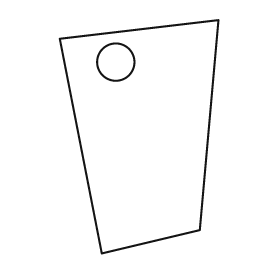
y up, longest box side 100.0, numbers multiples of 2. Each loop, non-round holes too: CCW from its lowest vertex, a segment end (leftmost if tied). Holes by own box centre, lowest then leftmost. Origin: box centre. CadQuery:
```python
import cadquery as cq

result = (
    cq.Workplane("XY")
    .moveTo(-16.0, -50.0)
    .lineTo(26.0, -40.0)
    .lineTo(34.0, 50.0)
    .lineTo(-34.0, 42.0)
    .close()
    .moveTo(-10.0, 32.0)
    .circle(8.0)
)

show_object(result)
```